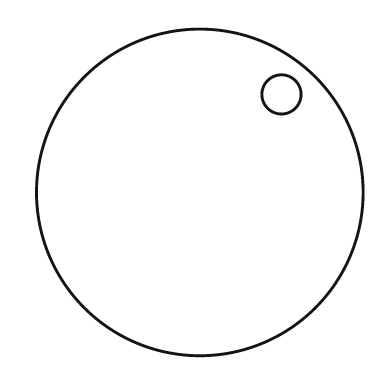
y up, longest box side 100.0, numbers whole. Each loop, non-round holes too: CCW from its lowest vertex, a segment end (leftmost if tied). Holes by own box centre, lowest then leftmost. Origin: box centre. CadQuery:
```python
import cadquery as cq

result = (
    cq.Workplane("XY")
    .moveTo(0.0, 0.0)
    .circle(50.0)
    .moveTo(25.0, 30.0)
    .circle(6.0)
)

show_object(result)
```